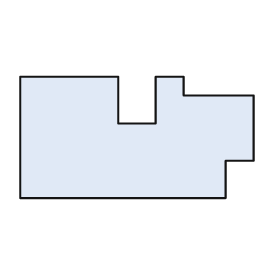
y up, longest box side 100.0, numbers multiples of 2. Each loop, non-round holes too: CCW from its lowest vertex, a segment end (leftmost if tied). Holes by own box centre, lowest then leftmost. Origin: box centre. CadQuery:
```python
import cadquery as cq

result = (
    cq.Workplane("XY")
    .moveTo(-50.0, -26.0)
    .lineTo(38.0, -26.0)
    .lineTo(38.0, -10.0)
    .lineTo(50.0, -10.0)
    .lineTo(50.0, 18.0)
    .lineTo(20.0, 18.0)
    .lineTo(20.0, 26.0)
    .lineTo(8.0, 26.0)
    .lineTo(8.0, 6.0)
    .lineTo(-8.0, 6.0)
    .lineTo(-8.0, 26.0)
    .lineTo(-50.0, 26.0)
    .close()
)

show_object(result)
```